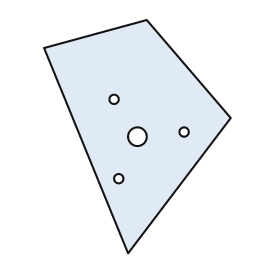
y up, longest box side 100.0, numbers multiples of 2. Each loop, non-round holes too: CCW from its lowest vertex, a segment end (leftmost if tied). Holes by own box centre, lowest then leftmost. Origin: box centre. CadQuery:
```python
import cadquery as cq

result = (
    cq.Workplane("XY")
    .moveTo(-4.0, -50.0)
    .lineTo(40.0, 8.0)
    .lineTo(4.0, 50.0)
    .lineTo(-40.0, 38.0)
    .close()
    .moveTo(-8.0, -18.0)
    .circle(2.0)
    .moveTo(0.0, 0.0)
    .circle(4.0)
    .moveTo(20.0, 2.0)
    .circle(2.0)
    .moveTo(-10.0, 16.0)
    .circle(2.0)
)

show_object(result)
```